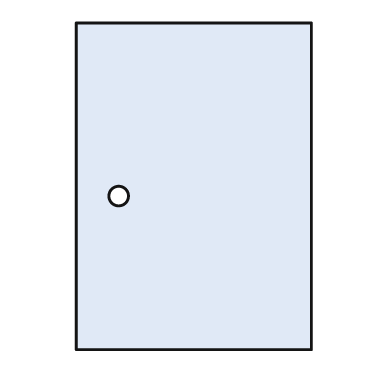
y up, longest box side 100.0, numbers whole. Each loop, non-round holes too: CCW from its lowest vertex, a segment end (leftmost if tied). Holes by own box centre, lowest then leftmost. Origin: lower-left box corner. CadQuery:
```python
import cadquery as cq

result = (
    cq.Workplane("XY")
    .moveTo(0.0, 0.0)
    .lineTo(72.0, 0.0)
    .lineTo(72.0, 100.0)
    .lineTo(0.0, 100.0)
    .close()
    .moveTo(13.0, 47.0)
    .circle(3.0)
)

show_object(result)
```